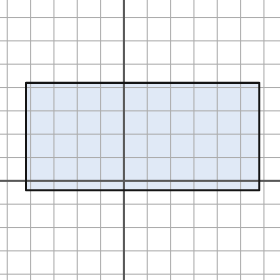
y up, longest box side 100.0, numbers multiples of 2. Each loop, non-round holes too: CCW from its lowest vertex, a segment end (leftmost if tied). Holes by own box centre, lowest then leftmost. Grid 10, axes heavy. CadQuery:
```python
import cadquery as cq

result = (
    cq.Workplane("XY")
    .moveTo(-42.0, -4.0)
    .lineTo(58.0, -4.0)
    .lineTo(58.0, 42.0)
    .lineTo(-42.0, 42.0)
    .close()
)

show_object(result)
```